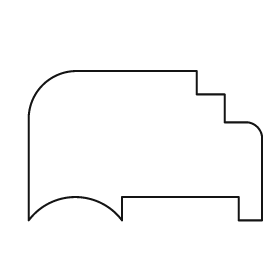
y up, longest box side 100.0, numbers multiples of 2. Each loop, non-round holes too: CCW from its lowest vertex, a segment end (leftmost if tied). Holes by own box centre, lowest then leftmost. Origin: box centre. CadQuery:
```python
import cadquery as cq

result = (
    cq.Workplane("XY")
    .moveTo(-50.0, -32.0)
    .threePointArc((-30.0, -22.0), (-10.0, -32.0))
    .lineTo(-10.0, -22.0)
    .lineTo(40.0, -22.0)
    .lineTo(40.0, -32.0)
    .lineTo(50.0, -32.0)
    .lineTo(50.0, 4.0)
    .threePointArc((48.0, 8.0), (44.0, 10.0))
    .lineTo(34.0, 10.0)
    .lineTo(34.0, 22.0)
    .lineTo(22.0, 22.0)
    .lineTo(22.0, 32.0)
    .lineTo(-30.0, 32.0)
    .threePointArc((-44.0, 26.0), (-50.0, 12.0))
    .close()
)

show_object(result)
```